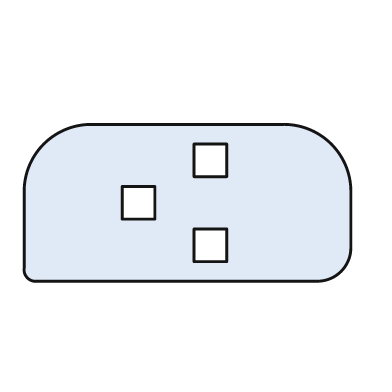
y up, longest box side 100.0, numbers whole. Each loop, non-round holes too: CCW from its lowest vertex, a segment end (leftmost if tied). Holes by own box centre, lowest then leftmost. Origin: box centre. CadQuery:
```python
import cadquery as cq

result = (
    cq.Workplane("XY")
    .moveTo(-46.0, -24.0)
    .lineTo(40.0, -24.0)
    .threePointArc((47.0, -21.0), (50.0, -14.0))
    .lineTo(50.0, 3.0)
    .threePointArc((44.0, 18.0), (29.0, 24.0))
    .lineTo(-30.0, 24.0)
    .threePointArc((-44.0, 18.0), (-50.0, 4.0))
    .lineTo(-50.0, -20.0)
    .threePointArc((-49.0, -23.0), (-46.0, -24.0))
    .close()
    .moveTo(2.0, -18.0)
    .lineTo(12.0, -18.0)
    .lineTo(12.0, -8.0)
    .lineTo(2.0, -8.0)
    .close()
    .moveTo(-20.0, -5.0)
    .lineTo(-10.0, -5.0)
    .lineTo(-10.0, 5.0)
    .lineTo(-20.0, 5.0)
    .close()
    .moveTo(2.0, 8.0)
    .lineTo(12.0, 8.0)
    .lineTo(12.0, 18.0)
    .lineTo(2.0, 18.0)
    .close()
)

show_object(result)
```